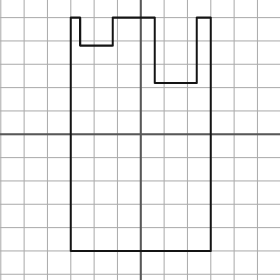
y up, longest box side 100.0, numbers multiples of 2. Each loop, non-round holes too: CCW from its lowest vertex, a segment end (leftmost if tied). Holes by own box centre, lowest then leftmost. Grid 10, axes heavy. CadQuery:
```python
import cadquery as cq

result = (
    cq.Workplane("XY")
    .moveTo(-30.0, -50.0)
    .lineTo(30.0, -50.0)
    .lineTo(30.0, 50.0)
    .lineTo(24.0, 50.0)
    .lineTo(24.0, 22.0)
    .lineTo(6.0, 22.0)
    .lineTo(6.0, 50.0)
    .lineTo(-12.0, 50.0)
    .lineTo(-12.0, 38.0)
    .lineTo(-26.0, 38.0)
    .lineTo(-26.0, 50.0)
    .lineTo(-30.0, 50.0)
    .close()
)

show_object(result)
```